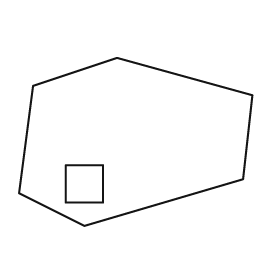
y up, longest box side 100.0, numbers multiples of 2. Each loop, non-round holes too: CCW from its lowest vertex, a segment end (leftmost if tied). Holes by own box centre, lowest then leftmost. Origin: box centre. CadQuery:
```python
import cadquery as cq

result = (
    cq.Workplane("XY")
    .moveTo(-22.0, -36.0)
    .lineTo(46.0, -16.0)
    .lineTo(50.0, 20.0)
    .lineTo(-8.0, 36.0)
    .lineTo(-44.0, 24.0)
    .lineTo(-50.0, -22.0)
    .close()
    .moveTo(-30.0, -26.0)
    .lineTo(-14.0, -26.0)
    .lineTo(-14.0, -10.0)
    .lineTo(-30.0, -10.0)
    .close()
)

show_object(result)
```